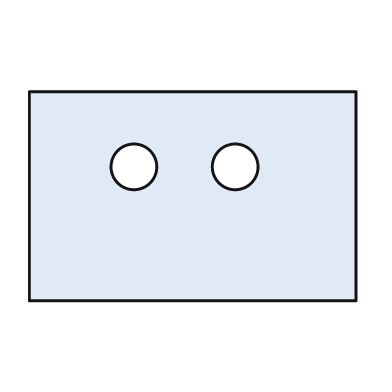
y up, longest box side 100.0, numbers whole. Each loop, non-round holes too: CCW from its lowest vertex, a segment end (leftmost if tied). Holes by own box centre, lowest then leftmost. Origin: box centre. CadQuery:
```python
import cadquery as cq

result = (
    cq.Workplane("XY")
    .moveTo(-50.0, -32.0)
    .lineTo(50.0, -32.0)
    .lineTo(50.0, 32.0)
    .lineTo(-50.0, 32.0)
    .close()
    .moveTo(-18.0, 9.0)
    .circle(7.0)
    .moveTo(13.0, 9.0)
    .circle(7.0)
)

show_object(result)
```